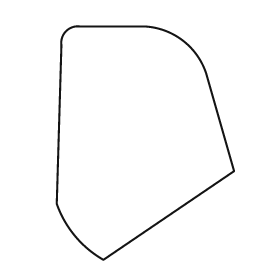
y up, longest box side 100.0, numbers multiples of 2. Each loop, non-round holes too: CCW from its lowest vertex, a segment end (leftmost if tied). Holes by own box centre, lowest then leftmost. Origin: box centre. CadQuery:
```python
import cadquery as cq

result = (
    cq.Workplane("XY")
    .moveTo(-18.0, -50.0)
    .lineTo(38.0, -12.0)
    .lineTo(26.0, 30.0)
    .threePointArc((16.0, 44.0), (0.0, 50.0))
    .lineTo(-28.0, 50.0)
    .threePointArc((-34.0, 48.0), (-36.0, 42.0))
    .lineTo(-38.0, -26.0)
    .threePointArc((-30.0, -40.0), (-18.0, -50.0))
    .close()
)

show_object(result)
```